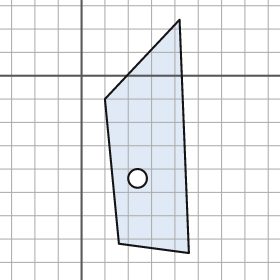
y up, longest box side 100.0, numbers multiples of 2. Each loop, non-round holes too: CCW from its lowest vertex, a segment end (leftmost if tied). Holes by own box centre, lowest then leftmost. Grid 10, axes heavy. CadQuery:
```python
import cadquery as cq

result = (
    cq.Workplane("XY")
    .moveTo(46.0, -76.0)
    .lineTo(42.0, 24.0)
    .lineTo(10.0, -10.0)
    .lineTo(16.0, -72.0)
    .close()
    .moveTo(24.0, -44.0)
    .circle(4.0)
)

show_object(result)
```